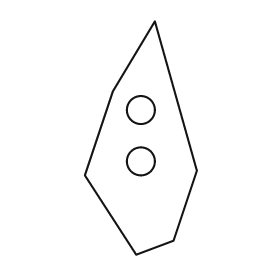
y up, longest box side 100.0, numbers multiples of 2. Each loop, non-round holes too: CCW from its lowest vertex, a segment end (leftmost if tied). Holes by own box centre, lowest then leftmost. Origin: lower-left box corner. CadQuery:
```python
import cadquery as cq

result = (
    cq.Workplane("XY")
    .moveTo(22.0, 0.0)
    .lineTo(38.0, 6.0)
    .lineTo(48.0, 36.0)
    .lineTo(30.0, 100.0)
    .lineTo(12.0, 70.0)
    .lineTo(0.0, 34.0)
    .close()
    .moveTo(24.0, 40.0)
    .circle(6.0)
    .moveTo(24.0, 62.0)
    .circle(6.0)
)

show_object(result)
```